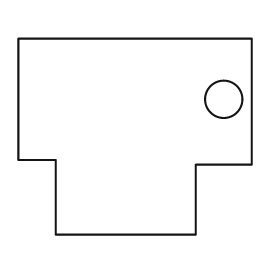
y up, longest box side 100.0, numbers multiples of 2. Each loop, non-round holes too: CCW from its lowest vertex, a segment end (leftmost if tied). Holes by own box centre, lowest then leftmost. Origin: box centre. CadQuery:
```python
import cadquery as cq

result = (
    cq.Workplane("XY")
    .moveTo(-34.0, -42.0)
    .lineTo(26.0, -42.0)
    .lineTo(26.0, -12.0)
    .lineTo(50.0, -12.0)
    .lineTo(50.0, 42.0)
    .lineTo(-50.0, 42.0)
    .lineTo(-50.0, -10.0)
    .lineTo(-34.0, -10.0)
    .close()
    .moveTo(38.0, 16.0)
    .circle(8.0)
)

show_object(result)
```